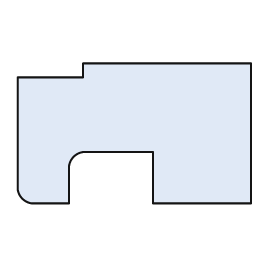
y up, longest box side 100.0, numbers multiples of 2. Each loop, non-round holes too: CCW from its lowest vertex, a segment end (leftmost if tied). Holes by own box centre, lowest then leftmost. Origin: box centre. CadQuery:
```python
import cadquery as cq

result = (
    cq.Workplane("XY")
    .moveTo(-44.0, -30.0)
    .lineTo(-28.0, -30.0)
    .lineTo(-28.0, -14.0)
    .threePointArc((-26.0, -10.0), (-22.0, -8.0))
    .lineTo(8.0, -8.0)
    .lineTo(8.0, -30.0)
    .lineTo(50.0, -30.0)
    .lineTo(50.0, 30.0)
    .lineTo(-22.0, 30.0)
    .lineTo(-22.0, 24.0)
    .lineTo(-50.0, 24.0)
    .lineTo(-50.0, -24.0)
    .threePointArc((-48.0, -28.0), (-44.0, -30.0))
    .close()
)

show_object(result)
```